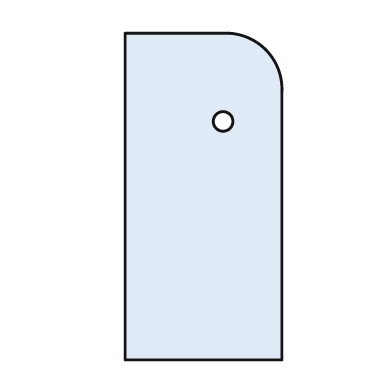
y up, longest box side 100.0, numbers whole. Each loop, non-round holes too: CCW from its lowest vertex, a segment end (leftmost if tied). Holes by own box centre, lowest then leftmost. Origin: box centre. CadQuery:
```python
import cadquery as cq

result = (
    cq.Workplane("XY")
    .moveTo(-24.0, -50.0)
    .lineTo(24.0, -50.0)
    .lineTo(24.0, 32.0)
    .threePointArc((19.0, 45.0), (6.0, 50.0))
    .lineTo(-24.0, 50.0)
    .close()
    .moveTo(6.0, 23.0)
    .circle(3.0)
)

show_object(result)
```